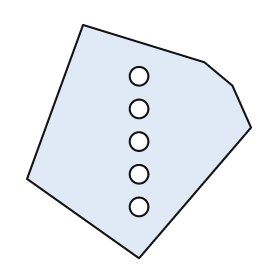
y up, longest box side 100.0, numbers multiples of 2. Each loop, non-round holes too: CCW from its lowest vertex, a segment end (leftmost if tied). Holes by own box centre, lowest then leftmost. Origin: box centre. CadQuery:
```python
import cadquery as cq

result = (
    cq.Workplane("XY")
    .moveTo(0.0, -50.0)
    .lineTo(48.0, 6.0)
    .lineTo(40.0, 24.0)
    .lineTo(28.0, 34.0)
    .lineTo(-24.0, 50.0)
    .lineTo(-48.0, -16.0)
    .close()
    .moveTo(0.0, -28.0)
    .circle(4.0)
    .moveTo(0.0, -14.0)
    .circle(4.0)
    .moveTo(0.0, 0.0)
    .circle(4.0)
    .moveTo(0.0, 14.0)
    .circle(4.0)
    .moveTo(0.0, 28.0)
    .circle(4.0)
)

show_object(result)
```